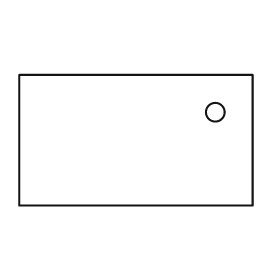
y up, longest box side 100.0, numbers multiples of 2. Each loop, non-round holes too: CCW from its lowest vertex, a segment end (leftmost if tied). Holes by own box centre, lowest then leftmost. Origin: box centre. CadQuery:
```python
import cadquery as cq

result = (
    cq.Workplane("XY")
    .moveTo(-50.0, -28.0)
    .lineTo(50.0, -28.0)
    .lineTo(50.0, 28.0)
    .lineTo(-50.0, 28.0)
    .close()
    .moveTo(34.0, 12.0)
    .circle(4.0)
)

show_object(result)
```